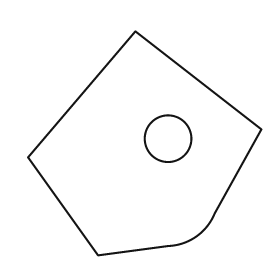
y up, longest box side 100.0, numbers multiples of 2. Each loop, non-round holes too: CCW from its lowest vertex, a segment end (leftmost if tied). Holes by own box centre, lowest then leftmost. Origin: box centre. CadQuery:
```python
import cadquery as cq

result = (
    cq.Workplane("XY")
    .moveTo(-20.0, -48.0)
    .lineTo(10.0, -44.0)
    .threePointArc((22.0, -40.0), (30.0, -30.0))
    .lineTo(50.0, 6.0)
    .lineTo(-4.0, 48.0)
    .lineTo(-50.0, -6.0)
    .close()
    .moveTo(10.0, 2.0)
    .circle(10.0)
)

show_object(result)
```